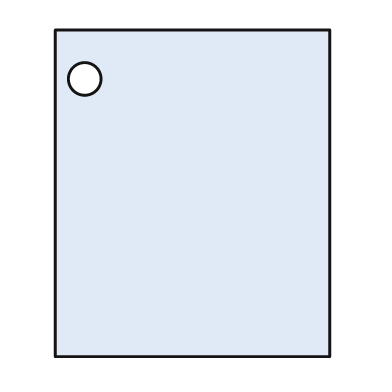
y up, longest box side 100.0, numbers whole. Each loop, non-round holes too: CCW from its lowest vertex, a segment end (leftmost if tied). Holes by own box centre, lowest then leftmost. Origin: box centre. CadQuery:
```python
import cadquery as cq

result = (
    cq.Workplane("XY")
    .moveTo(-42.0, -50.0)
    .lineTo(42.0, -50.0)
    .lineTo(42.0, 50.0)
    .lineTo(-42.0, 50.0)
    .close()
    .moveTo(-33.0, 35.0)
    .circle(5.0)
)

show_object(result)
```